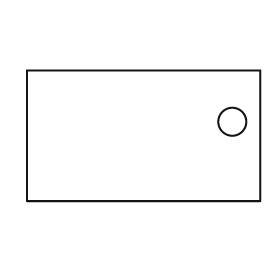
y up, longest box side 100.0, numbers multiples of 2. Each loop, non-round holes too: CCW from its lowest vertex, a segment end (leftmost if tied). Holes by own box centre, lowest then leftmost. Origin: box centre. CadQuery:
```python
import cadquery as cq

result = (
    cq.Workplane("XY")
    .moveTo(-50.0, -28.0)
    .lineTo(50.0, -28.0)
    .lineTo(50.0, 28.0)
    .lineTo(-50.0, 28.0)
    .close()
    .moveTo(38.0, 6.0)
    .circle(6.0)
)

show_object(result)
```